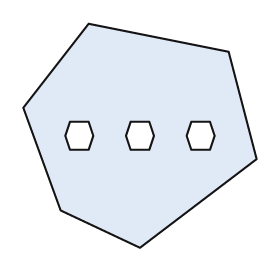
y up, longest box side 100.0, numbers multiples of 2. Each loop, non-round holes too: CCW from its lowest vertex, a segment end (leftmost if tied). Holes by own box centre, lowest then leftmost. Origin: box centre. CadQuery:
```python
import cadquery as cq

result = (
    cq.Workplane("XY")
    .moveTo(0.0, -48.0)
    .lineTo(50.0, -10.0)
    .lineTo(38.0, 36.0)
    .lineTo(-22.0, 48.0)
    .lineTo(-50.0, 12.0)
    .lineTo(-34.0, -32.0)
    .close()
    .moveTo(-30.0, -6.0)
    .lineTo(-22.0, -6.0)
    .lineTo(-20.0, 0.0)
    .lineTo(-22.0, 6.0)
    .lineTo(-30.0, 6.0)
    .lineTo(-32.0, 0.0)
    .close()
    .moveTo(-4.0, -6.0)
    .lineTo(4.0, -6.0)
    .lineTo(6.0, 0.0)
    .lineTo(4.0, 6.0)
    .lineTo(-4.0, 6.0)
    .lineTo(-6.0, 0.0)
    .close()
    .moveTo(22.0, -6.0)
    .lineTo(30.0, -6.0)
    .lineTo(32.0, 0.0)
    .lineTo(30.0, 6.0)
    .lineTo(22.0, 6.0)
    .lineTo(20.0, 0.0)
    .close()
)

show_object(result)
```